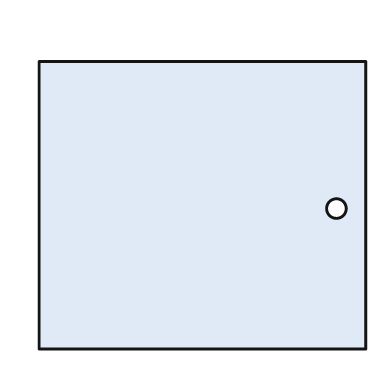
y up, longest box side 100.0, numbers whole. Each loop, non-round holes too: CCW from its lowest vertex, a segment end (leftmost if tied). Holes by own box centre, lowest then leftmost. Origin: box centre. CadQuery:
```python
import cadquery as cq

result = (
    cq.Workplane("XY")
    .moveTo(-50.0, -44.0)
    .lineTo(50.0, -44.0)
    .lineTo(50.0, 44.0)
    .lineTo(-50.0, 44.0)
    .close()
    .moveTo(41.0, -1.0)
    .circle(3.0)
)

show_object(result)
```